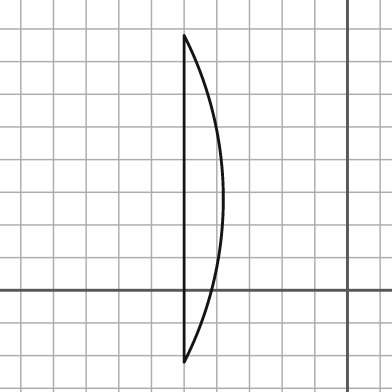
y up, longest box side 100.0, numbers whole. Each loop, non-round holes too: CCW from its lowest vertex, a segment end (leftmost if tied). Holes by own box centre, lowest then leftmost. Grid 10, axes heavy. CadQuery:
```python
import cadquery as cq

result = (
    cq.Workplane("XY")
    .moveTo(-50.0, -22.0)
    .threePointArc((-38.0, 28.0), (-50.0, 78.0))
    .close()
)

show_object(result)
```